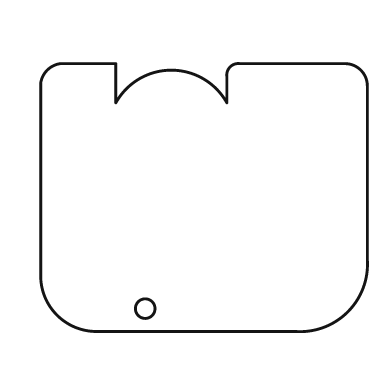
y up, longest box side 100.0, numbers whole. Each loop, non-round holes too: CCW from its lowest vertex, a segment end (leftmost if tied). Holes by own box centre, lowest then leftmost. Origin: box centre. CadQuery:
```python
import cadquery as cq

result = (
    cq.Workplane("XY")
    .moveTo(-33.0, -41.0)
    .lineTo(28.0, -41.0)
    .threePointArc((44.0, -35.0), (50.0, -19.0))
    .lineTo(50.0, 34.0)
    .threePointArc((48.0, 39.0), (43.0, 41.0))
    .lineTo(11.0, 41.0)
    .threePointArc((8.0, 40.0), (7.0, 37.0))
    .lineTo(7.0, 29.0)
    .threePointArc((-10.0, 39.0), (-27.0, 29.0))
    .lineTo(-27.0, 41.0)
    .lineTo(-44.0, 41.0)
    .threePointArc((-48.0, 39.0), (-50.0, 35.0))
    .lineTo(-50.0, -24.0)
    .threePointArc((-45.0, -36.0), (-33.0, -41.0))
    .close()
    .moveTo(-18.0, -34.0)
    .circle(3.0)
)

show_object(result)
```